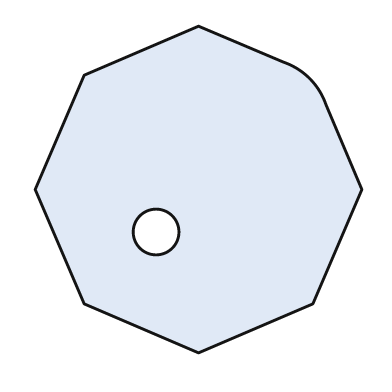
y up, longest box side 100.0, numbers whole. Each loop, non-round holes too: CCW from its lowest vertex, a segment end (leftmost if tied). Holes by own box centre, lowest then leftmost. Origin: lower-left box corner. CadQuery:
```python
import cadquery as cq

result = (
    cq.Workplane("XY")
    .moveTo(50.0, 0.0)
    .lineTo(85.0, 15.0)
    .lineTo(100.0, 50.0)
    .lineTo(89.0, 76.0)
    .threePointArc((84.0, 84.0), (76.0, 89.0))
    .lineTo(50.0, 100.0)
    .lineTo(15.0, 85.0)
    .lineTo(0.0, 50.0)
    .lineTo(15.0, 15.0)
    .close()
    .moveTo(37.0, 37.0)
    .circle(7.0)
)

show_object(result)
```